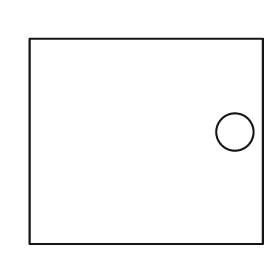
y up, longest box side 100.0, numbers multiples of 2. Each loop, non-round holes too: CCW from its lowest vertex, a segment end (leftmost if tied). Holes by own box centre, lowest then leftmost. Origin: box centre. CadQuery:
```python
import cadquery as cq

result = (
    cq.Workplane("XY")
    .moveTo(-50.0, -44.0)
    .lineTo(50.0, -44.0)
    .lineTo(50.0, 44.0)
    .lineTo(-50.0, 44.0)
    .close()
    .moveTo(38.0, 4.0)
    .circle(8.0)
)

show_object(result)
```